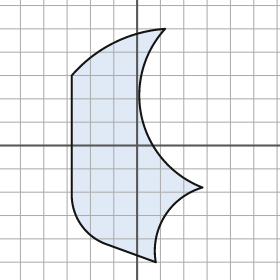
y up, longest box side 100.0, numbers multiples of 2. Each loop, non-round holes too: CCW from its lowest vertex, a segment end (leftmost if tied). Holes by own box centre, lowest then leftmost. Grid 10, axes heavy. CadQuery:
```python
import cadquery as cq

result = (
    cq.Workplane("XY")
    .moveTo(8.0, -50.0)
    .threePointArc((12.0, -30.0), (28.0, -18.0))
    .threePointArc((2.0, 12.0), (12.0, 50.0))
    .threePointArc((-10.0, 44.0), (-28.0, 30.0))
    .lineTo(-28.0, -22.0)
    .threePointArc((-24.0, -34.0), (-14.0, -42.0))
    .close()
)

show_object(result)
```